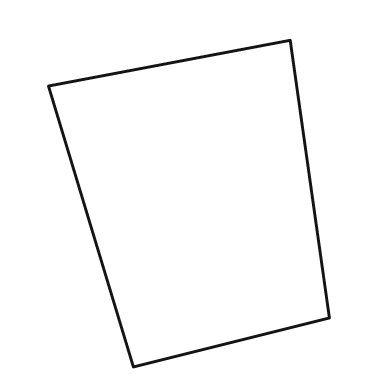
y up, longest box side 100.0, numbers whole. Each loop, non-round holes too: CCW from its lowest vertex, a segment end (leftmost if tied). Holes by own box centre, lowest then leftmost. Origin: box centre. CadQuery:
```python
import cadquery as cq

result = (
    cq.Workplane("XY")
    .moveTo(-17.0, -50.0)
    .lineTo(43.0, -35.0)
    .lineTo(31.0, 50.0)
    .lineTo(-43.0, 36.0)
    .close()
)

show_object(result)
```